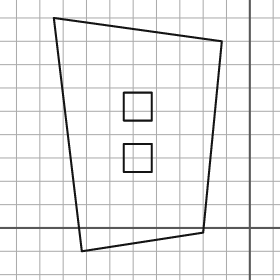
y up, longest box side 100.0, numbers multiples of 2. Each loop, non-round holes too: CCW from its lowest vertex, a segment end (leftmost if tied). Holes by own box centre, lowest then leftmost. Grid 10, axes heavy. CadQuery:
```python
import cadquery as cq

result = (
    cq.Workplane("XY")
    .moveTo(-72.0, -10.0)
    .lineTo(-20.0, -2.0)
    .lineTo(-12.0, 80.0)
    .lineTo(-84.0, 90.0)
    .close()
    .moveTo(-54.0, 24.0)
    .lineTo(-42.0, 24.0)
    .lineTo(-42.0, 36.0)
    .lineTo(-54.0, 36.0)
    .close()
    .moveTo(-54.0, 46.0)
    .lineTo(-42.0, 46.0)
    .lineTo(-42.0, 58.0)
    .lineTo(-54.0, 58.0)
    .close()
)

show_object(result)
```